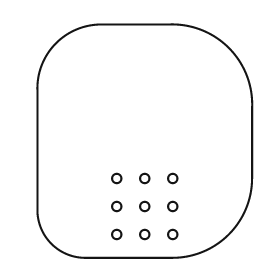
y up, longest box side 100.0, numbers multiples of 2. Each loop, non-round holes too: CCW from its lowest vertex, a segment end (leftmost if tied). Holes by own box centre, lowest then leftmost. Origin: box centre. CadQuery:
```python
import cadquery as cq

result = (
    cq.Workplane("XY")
    .moveTo(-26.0, -50.0)
    .lineTo(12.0, -50.0)
    .threePointArc((36.0, -40.0), (46.0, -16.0))
    .lineTo(46.0, 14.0)
    .threePointArc((36.0, 40.0), (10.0, 50.0))
    .lineTo(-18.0, 50.0)
    .threePointArc((-38.0, 42.0), (-46.0, 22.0))
    .lineTo(-46.0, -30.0)
    .threePointArc((-40.0, -44.0), (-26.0, -50.0))
    .close()
    .moveTo(-12.0, -40.0)
    .circle(2.0)
    .moveTo(0.0, -40.0)
    .circle(2.0)
    .moveTo(12.0, -40.0)
    .circle(2.0)
    .moveTo(-12.0, -28.0)
    .circle(2.0)
    .moveTo(0.0, -28.0)
    .circle(2.0)
    .moveTo(12.0, -28.0)
    .circle(2.0)
    .moveTo(-12.0, -16.0)
    .circle(2.0)
    .moveTo(0.0, -16.0)
    .circle(2.0)
    .moveTo(12.0, -16.0)
    .circle(2.0)
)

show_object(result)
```